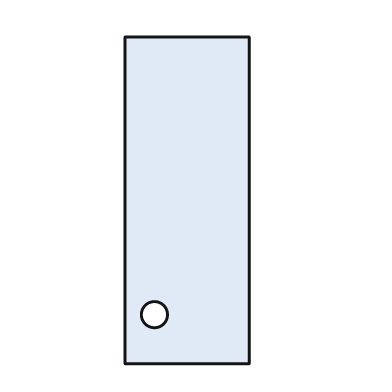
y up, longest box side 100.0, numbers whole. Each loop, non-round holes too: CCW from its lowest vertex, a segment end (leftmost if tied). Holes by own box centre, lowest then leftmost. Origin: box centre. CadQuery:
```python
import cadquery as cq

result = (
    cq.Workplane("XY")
    .moveTo(-19.0, -50.0)
    .lineTo(19.0, -50.0)
    .lineTo(19.0, 50.0)
    .lineTo(-19.0, 50.0)
    .close()
    .moveTo(-10.0, -35.0)
    .circle(4.0)
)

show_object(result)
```